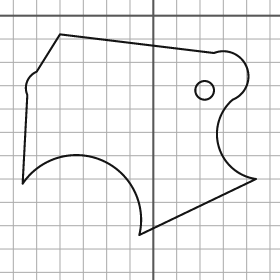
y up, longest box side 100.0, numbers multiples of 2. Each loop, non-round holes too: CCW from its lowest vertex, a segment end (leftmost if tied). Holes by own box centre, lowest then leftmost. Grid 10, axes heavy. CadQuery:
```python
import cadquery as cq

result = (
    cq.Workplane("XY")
    .moveTo(-6.0, -94.0)
    .lineTo(44.0, -70.0)
    .threePointArc((28.0, -56.0), (34.0, -36.0))
    .threePointArc((40.0, -22.0), (26.0, -16.0))
    .lineTo(-40.0, -8.0)
    .lineTo(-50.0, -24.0)
    .threePointArc((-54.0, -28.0), (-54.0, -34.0))
    .lineTo(-56.0, -72.0)
    .threePointArc((-22.0, -62.0), (-6.0, -94.0))
    .close()
    .moveTo(22.0, -32.0)
    .circle(4.0)
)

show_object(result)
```